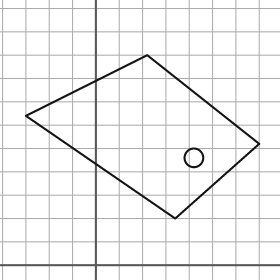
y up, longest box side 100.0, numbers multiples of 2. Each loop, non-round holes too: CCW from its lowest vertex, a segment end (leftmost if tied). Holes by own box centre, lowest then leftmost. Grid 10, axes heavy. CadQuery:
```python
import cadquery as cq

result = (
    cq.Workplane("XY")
    .moveTo(34.0, 20.0)
    .lineTo(70.0, 52.0)
    .lineTo(22.0, 90.0)
    .lineTo(-30.0, 64.0)
    .close()
    .moveTo(42.0, 46.0)
    .circle(4.0)
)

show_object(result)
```